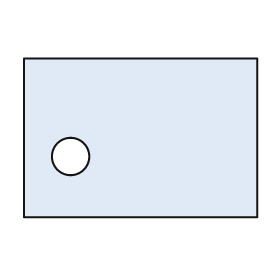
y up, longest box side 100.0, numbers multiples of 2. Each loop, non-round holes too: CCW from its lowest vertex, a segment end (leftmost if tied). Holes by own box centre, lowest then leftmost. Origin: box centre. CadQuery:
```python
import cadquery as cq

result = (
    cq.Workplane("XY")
    .moveTo(-50.0, -34.0)
    .lineTo(50.0, -34.0)
    .lineTo(50.0, 34.0)
    .lineTo(-50.0, 34.0)
    .close()
    .moveTo(-30.0, -8.0)
    .circle(8.0)
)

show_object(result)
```